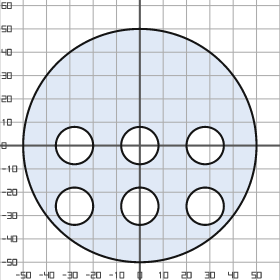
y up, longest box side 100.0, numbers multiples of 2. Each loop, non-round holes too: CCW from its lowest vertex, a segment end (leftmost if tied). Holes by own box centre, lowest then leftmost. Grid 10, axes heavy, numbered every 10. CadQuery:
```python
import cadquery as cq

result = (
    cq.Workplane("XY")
    .moveTo(0.0, 0.0)
    .circle(50.0)
    .moveTo(-28.0, -26.0)
    .circle(8.0)
    .moveTo(0.0, -26.0)
    .circle(8.0)
    .moveTo(28.0, -26.0)
    .circle(8.0)
    .moveTo(-28.0, 0.0)
    .circle(8.0)
    .moveTo(0.0, 0.0)
    .circle(8.0)
    .moveTo(28.0, 0.0)
    .circle(8.0)
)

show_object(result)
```